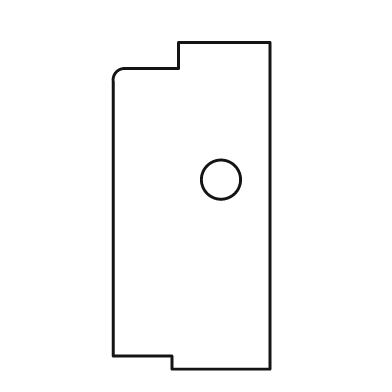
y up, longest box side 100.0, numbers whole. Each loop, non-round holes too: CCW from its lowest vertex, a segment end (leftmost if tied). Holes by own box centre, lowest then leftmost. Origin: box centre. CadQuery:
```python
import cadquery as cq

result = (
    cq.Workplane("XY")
    .moveTo(-6.0, -50.0)
    .lineTo(24.0, -50.0)
    .lineTo(24.0, 50.0)
    .lineTo(-4.0, 50.0)
    .lineTo(-4.0, 42.0)
    .lineTo(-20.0, 42.0)
    .threePointArc((-23.0, 41.0), (-24.0, 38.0))
    .lineTo(-24.0, -46.0)
    .lineTo(-6.0, -46.0)
    .close()
    .moveTo(9.0, 8.0)
    .circle(6.0)
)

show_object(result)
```